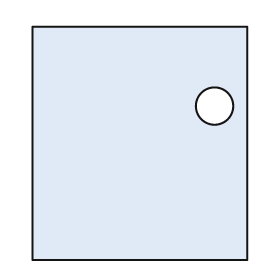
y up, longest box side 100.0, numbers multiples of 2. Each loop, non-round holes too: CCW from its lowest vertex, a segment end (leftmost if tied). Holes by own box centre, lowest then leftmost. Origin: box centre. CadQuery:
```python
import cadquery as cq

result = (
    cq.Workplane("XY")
    .moveTo(-46.0, -50.0)
    .lineTo(46.0, -50.0)
    .lineTo(46.0, 50.0)
    .lineTo(-46.0, 50.0)
    .close()
    .moveTo(32.0, 16.0)
    .circle(8.0)
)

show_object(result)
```